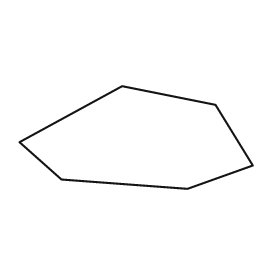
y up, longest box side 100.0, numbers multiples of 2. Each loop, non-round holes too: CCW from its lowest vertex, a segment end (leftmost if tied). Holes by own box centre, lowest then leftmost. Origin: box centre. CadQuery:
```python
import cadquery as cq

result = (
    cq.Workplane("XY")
    .moveTo(22.0, -22.0)
    .lineTo(50.0, -12.0)
    .lineTo(34.0, 14.0)
    .lineTo(-6.0, 22.0)
    .lineTo(-50.0, -2.0)
    .lineTo(-32.0, -18.0)
    .close()
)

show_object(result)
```